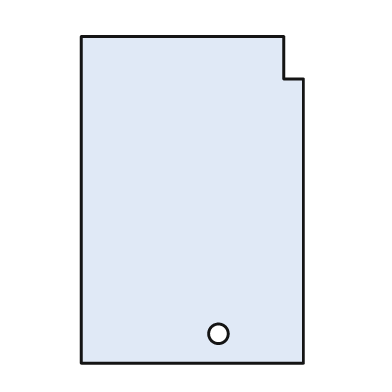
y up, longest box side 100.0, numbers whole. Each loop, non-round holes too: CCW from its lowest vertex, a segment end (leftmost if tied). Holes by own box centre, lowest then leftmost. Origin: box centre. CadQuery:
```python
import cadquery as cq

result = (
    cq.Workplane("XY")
    .moveTo(-34.0, -50.0)
    .lineTo(34.0, -50.0)
    .lineTo(34.0, 37.0)
    .lineTo(28.0, 37.0)
    .lineTo(28.0, 50.0)
    .lineTo(-34.0, 50.0)
    .close()
    .moveTo(8.0, -41.0)
    .circle(3.0)
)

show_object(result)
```